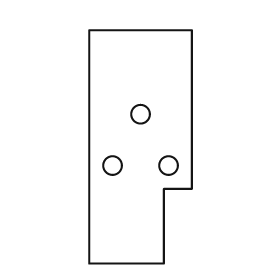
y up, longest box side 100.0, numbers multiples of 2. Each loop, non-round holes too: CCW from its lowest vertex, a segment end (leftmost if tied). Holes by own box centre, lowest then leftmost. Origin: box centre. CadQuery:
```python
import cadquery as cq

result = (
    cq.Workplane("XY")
    .moveTo(-22.0, -50.0)
    .lineTo(10.0, -50.0)
    .lineTo(10.0, -18.0)
    .lineTo(22.0, -18.0)
    .lineTo(22.0, 50.0)
    .lineTo(-22.0, 50.0)
    .close()
    .moveTo(-12.0, -8.0)
    .circle(4.0)
    .moveTo(12.0, -8.0)
    .circle(4.0)
    .moveTo(0.0, 14.0)
    .circle(4.0)
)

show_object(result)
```